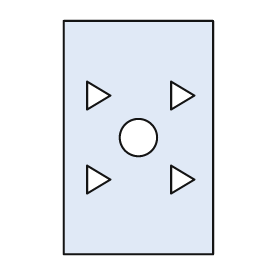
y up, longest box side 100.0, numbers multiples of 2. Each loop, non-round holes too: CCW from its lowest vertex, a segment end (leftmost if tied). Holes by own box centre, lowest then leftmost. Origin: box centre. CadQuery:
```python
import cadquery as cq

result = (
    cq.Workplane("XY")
    .moveTo(-32.0, -50.0)
    .lineTo(32.0, -50.0)
    .lineTo(32.0, 50.0)
    .lineTo(-32.0, 50.0)
    .close()
    .moveTo(-22.0, -24.0)
    .lineTo(-12.0, -18.0)
    .lineTo(-22.0, -12.0)
    .close()
    .moveTo(14.0, -24.0)
    .lineTo(24.0, -18.0)
    .lineTo(14.0, -12.0)
    .close()
    .moveTo(0.0, 0.0)
    .circle(8.0)
    .moveTo(-22.0, 12.0)
    .lineTo(-12.0, 18.0)
    .lineTo(-22.0, 24.0)
    .close()
    .moveTo(14.0, 12.0)
    .lineTo(24.0, 18.0)
    .lineTo(14.0, 24.0)
    .close()
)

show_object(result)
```